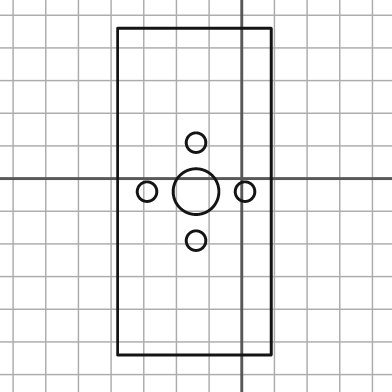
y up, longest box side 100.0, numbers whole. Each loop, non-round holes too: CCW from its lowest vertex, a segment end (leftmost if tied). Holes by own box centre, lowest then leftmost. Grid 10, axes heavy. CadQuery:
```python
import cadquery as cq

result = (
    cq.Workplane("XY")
    .moveTo(-38.0, -54.0)
    .lineTo(9.0, -54.0)
    .lineTo(9.0, 46.0)
    .lineTo(-38.0, 46.0)
    .close()
    .moveTo(-14.0, -19.0)
    .circle(3.0)
    .moveTo(-29.0, -4.0)
    .circle(3.0)
    .moveTo(-14.0, -4.0)
    .circle(7.0)
    .moveTo(1.0, -4.0)
    .circle(3.0)
    .moveTo(-14.0, 11.0)
    .circle(3.0)
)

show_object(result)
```